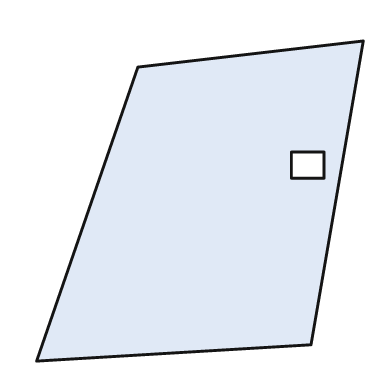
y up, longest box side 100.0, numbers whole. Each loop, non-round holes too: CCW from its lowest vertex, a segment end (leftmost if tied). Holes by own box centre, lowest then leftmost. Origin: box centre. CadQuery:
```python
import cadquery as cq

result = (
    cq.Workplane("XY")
    .moveTo(-50.0, -49.0)
    .lineTo(34.0, -44.0)
    .lineTo(50.0, 49.0)
    .lineTo(-19.0, 41.0)
    .close()
    .moveTo(28.0, 7.0)
    .lineTo(38.0, 7.0)
    .lineTo(38.0, 15.0)
    .lineTo(28.0, 15.0)
    .close()
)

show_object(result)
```